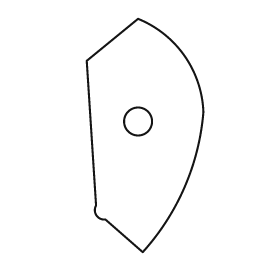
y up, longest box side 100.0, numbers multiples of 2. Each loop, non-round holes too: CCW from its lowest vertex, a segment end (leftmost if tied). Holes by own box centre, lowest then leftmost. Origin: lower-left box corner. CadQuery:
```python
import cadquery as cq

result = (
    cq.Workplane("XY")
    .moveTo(24.0, 0.0)
    .threePointArc((42.0, 28.0), (50.0, 60.0))
    .threePointArc((42.0, 84.0), (22.0, 100.0))
    .lineTo(0.0, 82.0)
    .lineTo(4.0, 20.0)
    .threePointArc((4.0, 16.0), (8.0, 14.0))
    .close()
    .moveTo(22.0, 56.0)
    .circle(6.0)
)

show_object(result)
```